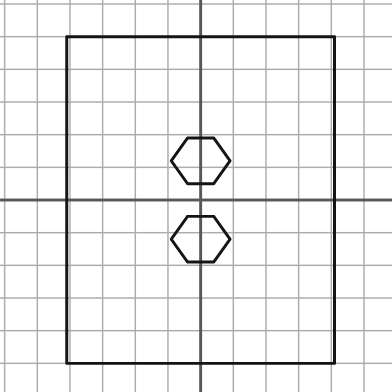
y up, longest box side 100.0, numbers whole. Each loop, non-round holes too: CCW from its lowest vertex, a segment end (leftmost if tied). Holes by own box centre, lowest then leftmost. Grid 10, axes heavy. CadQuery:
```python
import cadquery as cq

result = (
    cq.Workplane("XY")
    .moveTo(-41.0, -50.0)
    .lineTo(41.0, -50.0)
    .lineTo(41.0, 50.0)
    .lineTo(-41.0, 50.0)
    .close()
    .moveTo(-4.0, -19.0)
    .lineTo(4.0, -19.0)
    .lineTo(9.0, -12.0)
    .lineTo(4.0, -5.0)
    .lineTo(-4.0, -5.0)
    .lineTo(-9.0, -12.0)
    .close()
    .moveTo(-4.0, 5.0)
    .lineTo(4.0, 5.0)
    .lineTo(9.0, 12.0)
    .lineTo(4.0, 19.0)
    .lineTo(-4.0, 19.0)
    .lineTo(-9.0, 12.0)
    .close()
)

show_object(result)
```